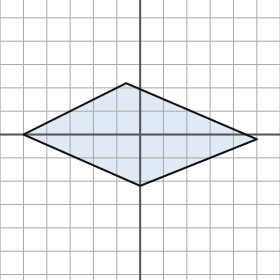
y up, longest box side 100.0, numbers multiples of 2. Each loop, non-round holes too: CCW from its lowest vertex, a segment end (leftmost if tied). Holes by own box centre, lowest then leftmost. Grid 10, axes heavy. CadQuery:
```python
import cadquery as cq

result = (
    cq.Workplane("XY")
    .moveTo(0.0, -22.0)
    .lineTo(50.0, -2.0)
    .lineTo(-6.0, 22.0)
    .lineTo(-50.0, 0.0)
    .close()
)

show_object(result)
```